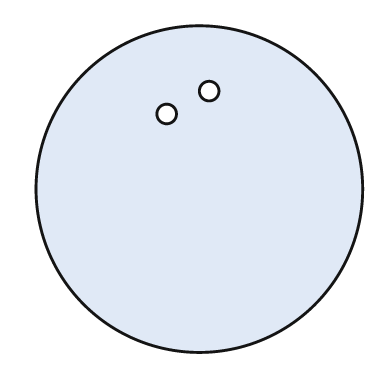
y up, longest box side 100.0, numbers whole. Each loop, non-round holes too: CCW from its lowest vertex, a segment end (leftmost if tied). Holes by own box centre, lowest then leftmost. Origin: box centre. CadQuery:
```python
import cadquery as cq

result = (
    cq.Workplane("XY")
    .moveTo(0.0, 0.0)
    .circle(50.0)
    .moveTo(-10.0, 23.0)
    .circle(3.0)
    .moveTo(3.0, 30.0)
    .circle(3.0)
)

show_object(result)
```